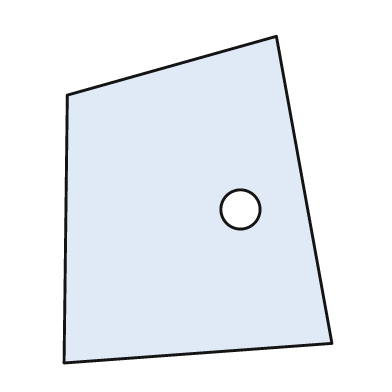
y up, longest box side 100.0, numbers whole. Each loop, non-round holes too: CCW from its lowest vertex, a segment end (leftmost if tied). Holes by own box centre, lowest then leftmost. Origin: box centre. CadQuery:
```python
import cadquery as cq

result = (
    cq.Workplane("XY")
    .moveTo(-41.0, -50.0)
    .lineTo(41.0, -44.0)
    .lineTo(24.0, 50.0)
    .lineTo(-40.0, 32.0)
    .close()
    .moveTo(13.0, -3.0)
    .circle(6.0)
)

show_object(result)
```